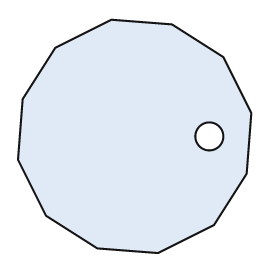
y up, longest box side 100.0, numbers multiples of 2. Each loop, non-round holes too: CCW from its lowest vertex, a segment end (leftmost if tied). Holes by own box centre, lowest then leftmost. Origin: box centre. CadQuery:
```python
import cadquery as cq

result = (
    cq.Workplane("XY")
    .moveTo(10.0, -50.0)
    .lineTo(34.0, -38.0)
    .lineTo(48.0, -16.0)
    .lineTo(50.0, 10.0)
    .lineTo(38.0, 34.0)
    .lineTo(16.0, 48.0)
    .lineTo(-10.0, 50.0)
    .lineTo(-34.0, 38.0)
    .lineTo(-48.0, 16.0)
    .lineTo(-50.0, -10.0)
    .lineTo(-38.0, -34.0)
    .lineTo(-16.0, -48.0)
    .close()
    .moveTo(32.0, 0.0)
    .circle(6.0)
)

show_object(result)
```